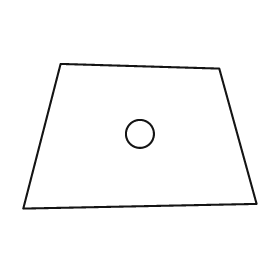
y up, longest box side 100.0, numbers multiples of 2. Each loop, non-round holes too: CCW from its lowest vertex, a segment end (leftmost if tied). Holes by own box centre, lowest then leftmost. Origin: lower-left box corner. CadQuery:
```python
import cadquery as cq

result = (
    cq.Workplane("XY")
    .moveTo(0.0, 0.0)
    .lineTo(100.0, 2.0)
    .lineTo(84.0, 60.0)
    .lineTo(16.0, 62.0)
    .close()
    .moveTo(50.0, 32.0)
    .circle(6.0)
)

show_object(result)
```